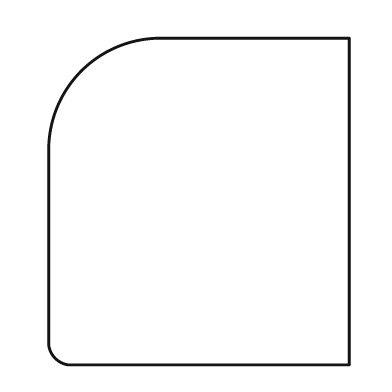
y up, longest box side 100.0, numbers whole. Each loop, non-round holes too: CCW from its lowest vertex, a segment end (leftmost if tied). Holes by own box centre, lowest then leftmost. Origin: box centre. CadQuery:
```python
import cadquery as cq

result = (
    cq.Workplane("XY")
    .moveTo(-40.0, -50.0)
    .lineTo(46.0, -50.0)
    .lineTo(46.0, 50.0)
    .lineTo(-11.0, 50.0)
    .threePointArc((-36.0, 40.0), (-46.0, 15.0))
    .lineTo(-46.0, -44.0)
    .threePointArc((-44.0, -48.0), (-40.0, -50.0))
    .close()
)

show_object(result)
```